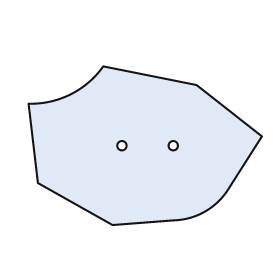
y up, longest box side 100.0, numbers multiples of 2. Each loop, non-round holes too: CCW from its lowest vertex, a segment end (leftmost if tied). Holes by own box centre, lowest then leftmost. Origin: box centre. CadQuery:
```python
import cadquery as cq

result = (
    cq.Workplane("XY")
    .moveTo(-14.0, -34.0)
    .lineTo(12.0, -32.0)
    .threePointArc((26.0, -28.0), (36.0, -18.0))
    .lineTo(50.0, 4.0)
    .lineTo(22.0, 26.0)
    .lineTo(-18.0, 34.0)
    .threePointArc((-32.0, 22.0), (-50.0, 18.0))
    .lineTo(-46.0, -16.0)
    .close()
    .moveTo(-10.0, 0.0)
    .circle(2.0)
    .moveTo(12.0, 0.0)
    .circle(2.0)
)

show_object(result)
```